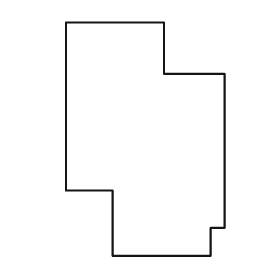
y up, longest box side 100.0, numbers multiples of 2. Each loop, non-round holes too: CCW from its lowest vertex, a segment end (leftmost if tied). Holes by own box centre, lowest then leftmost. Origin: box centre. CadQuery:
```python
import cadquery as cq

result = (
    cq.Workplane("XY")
    .moveTo(-14.0, -50.0)
    .lineTo(28.0, -50.0)
    .lineTo(28.0, -38.0)
    .lineTo(34.0, -38.0)
    .lineTo(34.0, 28.0)
    .lineTo(8.0, 28.0)
    .lineTo(8.0, 50.0)
    .lineTo(-34.0, 50.0)
    .lineTo(-34.0, -22.0)
    .lineTo(-14.0, -22.0)
    .close()
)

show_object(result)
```